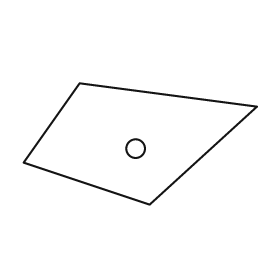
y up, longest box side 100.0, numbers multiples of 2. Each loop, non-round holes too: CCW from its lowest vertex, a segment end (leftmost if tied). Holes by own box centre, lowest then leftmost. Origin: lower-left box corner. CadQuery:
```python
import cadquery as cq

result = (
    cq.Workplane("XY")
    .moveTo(54.0, 0.0)
    .lineTo(100.0, 42.0)
    .lineTo(24.0, 52.0)
    .lineTo(0.0, 18.0)
    .close()
    .moveTo(48.0, 24.0)
    .circle(4.0)
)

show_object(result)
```